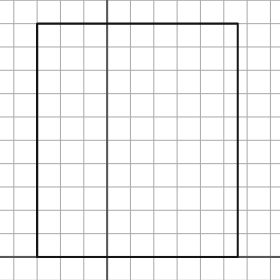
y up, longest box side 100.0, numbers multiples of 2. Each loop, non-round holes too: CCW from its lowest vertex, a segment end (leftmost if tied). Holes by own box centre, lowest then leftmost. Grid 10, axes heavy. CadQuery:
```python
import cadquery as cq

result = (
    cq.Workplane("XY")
    .moveTo(-30.0, 0.0)
    .lineTo(56.0, 0.0)
    .lineTo(56.0, 100.0)
    .lineTo(-30.0, 100.0)
    .close()
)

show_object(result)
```